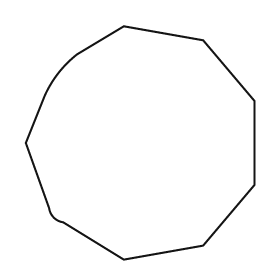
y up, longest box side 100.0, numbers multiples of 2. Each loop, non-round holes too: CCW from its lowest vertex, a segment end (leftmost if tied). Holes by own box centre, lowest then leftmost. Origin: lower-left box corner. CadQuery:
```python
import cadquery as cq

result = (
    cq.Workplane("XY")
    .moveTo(42.0, 0.0)
    .lineTo(76.0, 6.0)
    .lineTo(98.0, 32.0)
    .lineTo(98.0, 68.0)
    .lineTo(76.0, 94.0)
    .lineTo(42.0, 100.0)
    .lineTo(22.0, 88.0)
    .threePointArc((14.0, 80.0), (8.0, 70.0))
    .lineTo(0.0, 50.0)
    .lineTo(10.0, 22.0)
    .threePointArc((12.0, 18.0), (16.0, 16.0))
    .close()
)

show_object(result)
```